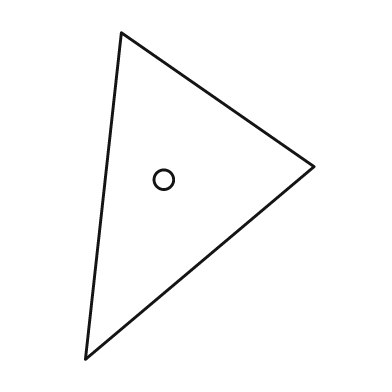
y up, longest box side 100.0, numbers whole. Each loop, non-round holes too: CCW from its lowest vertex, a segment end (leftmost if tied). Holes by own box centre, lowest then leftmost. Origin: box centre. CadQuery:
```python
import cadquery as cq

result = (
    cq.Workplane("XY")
    .moveTo(-35.0, -50.0)
    .lineTo(35.0, 9.0)
    .lineTo(-24.0, 50.0)
    .close()
    .moveTo(-11.0, 5.0)
    .circle(3.0)
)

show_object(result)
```